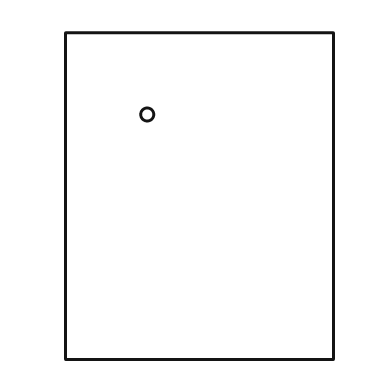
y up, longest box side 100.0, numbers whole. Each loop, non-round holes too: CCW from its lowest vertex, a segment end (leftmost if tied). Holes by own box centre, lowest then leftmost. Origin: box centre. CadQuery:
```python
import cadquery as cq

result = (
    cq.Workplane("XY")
    .moveTo(-41.0, -50.0)
    .lineTo(41.0, -50.0)
    .lineTo(41.0, 50.0)
    .lineTo(-41.0, 50.0)
    .close()
    .moveTo(-16.0, 25.0)
    .circle(2.0)
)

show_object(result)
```